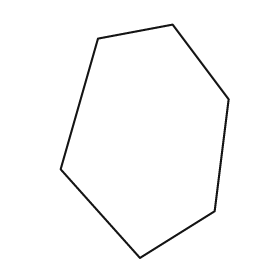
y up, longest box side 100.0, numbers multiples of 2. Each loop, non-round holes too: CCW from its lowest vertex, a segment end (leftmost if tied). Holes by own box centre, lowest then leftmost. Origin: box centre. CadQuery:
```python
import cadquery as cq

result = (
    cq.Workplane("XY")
    .moveTo(-2.0, -50.0)
    .lineTo(30.0, -30.0)
    .lineTo(36.0, 18.0)
    .lineTo(12.0, 50.0)
    .lineTo(-20.0, 44.0)
    .lineTo(-36.0, -12.0)
    .close()
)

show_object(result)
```